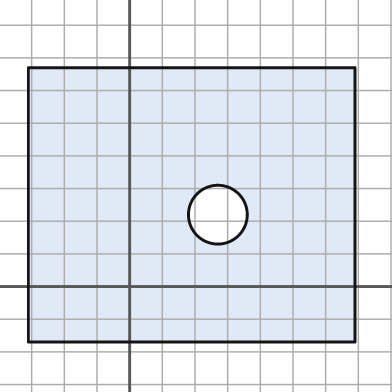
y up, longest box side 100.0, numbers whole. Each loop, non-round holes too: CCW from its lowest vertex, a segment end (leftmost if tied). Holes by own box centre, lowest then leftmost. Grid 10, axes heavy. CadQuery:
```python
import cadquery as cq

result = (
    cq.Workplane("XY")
    .moveTo(-31.0, -17.0)
    .lineTo(69.0, -17.0)
    .lineTo(69.0, 67.0)
    .lineTo(-31.0, 67.0)
    .close()
    .moveTo(27.0, 22.0)
    .circle(9.0)
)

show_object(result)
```